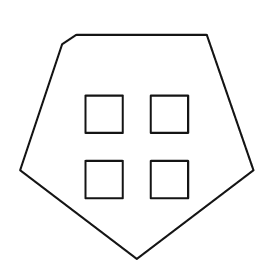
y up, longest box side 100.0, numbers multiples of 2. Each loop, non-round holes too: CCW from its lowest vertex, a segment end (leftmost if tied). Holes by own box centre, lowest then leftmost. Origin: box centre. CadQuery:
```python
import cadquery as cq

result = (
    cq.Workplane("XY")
    .moveTo(0.0, -48.0)
    .lineTo(50.0, -10.0)
    .lineTo(30.0, 48.0)
    .lineTo(-26.0, 48.0)
    .lineTo(-32.0, 44.0)
    .lineTo(-50.0, -10.0)
    .close()
    .moveTo(-22.0, -22.0)
    .lineTo(-6.0, -22.0)
    .lineTo(-6.0, -6.0)
    .lineTo(-22.0, -6.0)
    .close()
    .moveTo(6.0, -22.0)
    .lineTo(22.0, -22.0)
    .lineTo(22.0, -6.0)
    .lineTo(6.0, -6.0)
    .close()
    .moveTo(-22.0, 6.0)
    .lineTo(-6.0, 6.0)
    .lineTo(-6.0, 22.0)
    .lineTo(-22.0, 22.0)
    .close()
    .moveTo(6.0, 6.0)
    .lineTo(22.0, 6.0)
    .lineTo(22.0, 22.0)
    .lineTo(6.0, 22.0)
    .close()
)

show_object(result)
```